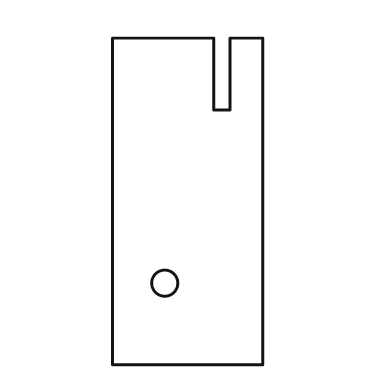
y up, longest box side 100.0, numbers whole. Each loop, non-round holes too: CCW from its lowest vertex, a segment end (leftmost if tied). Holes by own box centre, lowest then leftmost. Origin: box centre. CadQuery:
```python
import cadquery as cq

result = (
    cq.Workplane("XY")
    .moveTo(-23.0, -50.0)
    .lineTo(23.0, -50.0)
    .lineTo(23.0, 50.0)
    .lineTo(13.0, 50.0)
    .lineTo(13.0, 28.0)
    .lineTo(8.0, 28.0)
    .lineTo(8.0, 50.0)
    .lineTo(-23.0, 50.0)
    .close()
    .moveTo(-7.0, -25.0)
    .circle(4.0)
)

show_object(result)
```